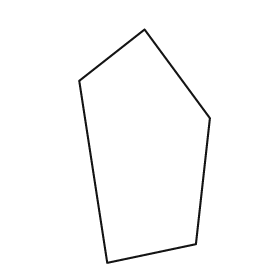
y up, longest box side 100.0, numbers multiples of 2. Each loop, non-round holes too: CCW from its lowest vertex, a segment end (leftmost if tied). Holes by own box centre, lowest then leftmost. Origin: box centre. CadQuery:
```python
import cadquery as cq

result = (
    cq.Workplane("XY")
    .moveTo(-16.0, -50.0)
    .lineTo(22.0, -42.0)
    .lineTo(28.0, 12.0)
    .lineTo(0.0, 50.0)
    .lineTo(-28.0, 28.0)
    .close()
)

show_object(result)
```